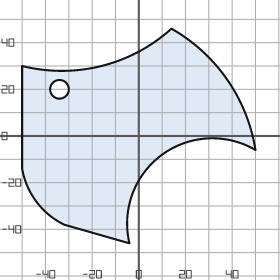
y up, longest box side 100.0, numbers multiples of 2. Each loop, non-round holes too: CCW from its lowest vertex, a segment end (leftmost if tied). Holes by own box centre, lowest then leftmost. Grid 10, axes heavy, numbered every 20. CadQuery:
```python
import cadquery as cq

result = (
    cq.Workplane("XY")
    .moveTo(-4.0, -46.0)
    .threePointArc((10.0, -8.0), (50.0, -6.0))
    .threePointArc((38.0, 24.0), (14.0, 46.0))
    .threePointArc((-16.0, 30.0), (-50.0, 30.0))
    .lineTo(-50.0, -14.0)
    .threePointArc((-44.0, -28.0), (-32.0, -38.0))
    .close()
    .moveTo(-34.0, 20.0)
    .circle(4.0)
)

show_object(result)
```